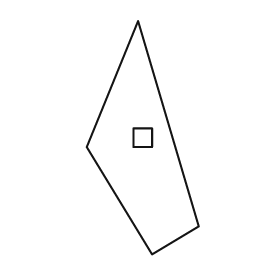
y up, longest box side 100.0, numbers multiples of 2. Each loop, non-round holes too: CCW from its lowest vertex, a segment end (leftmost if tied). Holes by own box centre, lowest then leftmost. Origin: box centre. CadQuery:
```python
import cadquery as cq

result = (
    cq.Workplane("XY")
    .moveTo(4.0, -50.0)
    .lineTo(24.0, -38.0)
    .lineTo(-2.0, 50.0)
    .lineTo(-24.0, -4.0)
    .close()
    .moveTo(-4.0, -4.0)
    .lineTo(4.0, -4.0)
    .lineTo(4.0, 4.0)
    .lineTo(-4.0, 4.0)
    .close()
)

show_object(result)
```